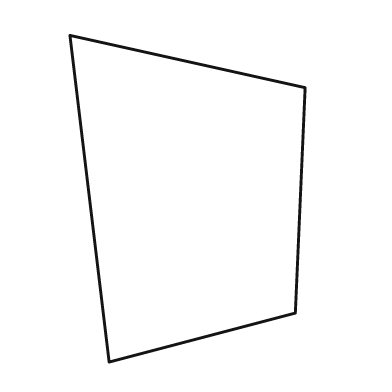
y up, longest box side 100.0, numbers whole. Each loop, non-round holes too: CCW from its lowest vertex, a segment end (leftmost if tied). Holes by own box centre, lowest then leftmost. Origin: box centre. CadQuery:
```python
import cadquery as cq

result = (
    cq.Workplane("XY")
    .moveTo(-24.0, -50.0)
    .lineTo(33.0, -35.0)
    .lineTo(36.0, 34.0)
    .lineTo(-36.0, 50.0)
    .close()
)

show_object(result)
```